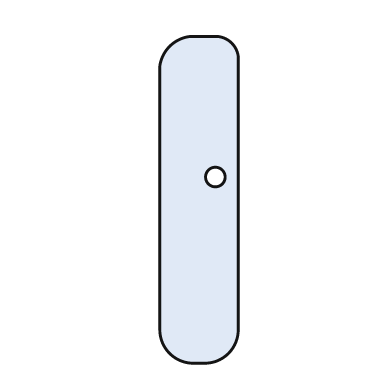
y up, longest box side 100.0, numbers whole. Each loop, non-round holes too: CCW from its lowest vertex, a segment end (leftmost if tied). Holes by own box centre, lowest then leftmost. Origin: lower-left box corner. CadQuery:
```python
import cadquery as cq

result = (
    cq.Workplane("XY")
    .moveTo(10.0, 0.0)
    .lineTo(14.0, 0.0)
    .threePointArc((21.0, 3.0), (24.0, 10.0))
    .lineTo(24.0, 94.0)
    .threePointArc((22.0, 98.0), (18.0, 100.0))
    .lineTo(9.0, 100.0)
    .threePointArc((3.0, 97.0), (0.0, 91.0))
    .lineTo(0.0, 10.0)
    .threePointArc((3.0, 3.0), (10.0, 0.0))
    .close()
    .moveTo(17.0, 57.0)
    .circle(3.0)
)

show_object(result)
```